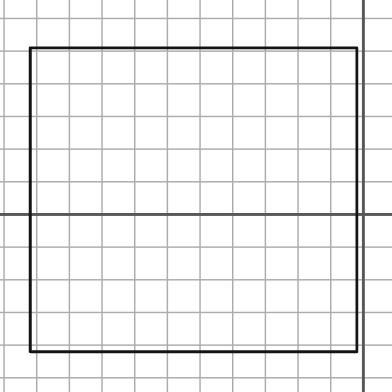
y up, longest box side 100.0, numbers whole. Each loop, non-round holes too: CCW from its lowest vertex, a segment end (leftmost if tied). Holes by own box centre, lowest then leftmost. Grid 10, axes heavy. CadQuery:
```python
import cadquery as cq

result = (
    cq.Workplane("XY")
    .moveTo(-102.0, -42.0)
    .lineTo(-2.0, -42.0)
    .lineTo(-2.0, 51.0)
    .lineTo(-102.0, 51.0)
    .close()
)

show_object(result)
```